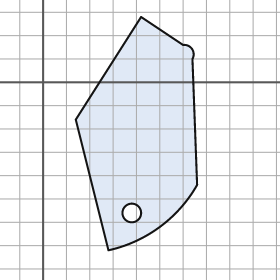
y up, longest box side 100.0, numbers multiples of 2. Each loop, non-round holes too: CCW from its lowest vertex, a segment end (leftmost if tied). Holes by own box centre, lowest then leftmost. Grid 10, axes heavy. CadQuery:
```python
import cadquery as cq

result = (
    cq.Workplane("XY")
    .moveTo(28.0, -72.0)
    .threePointArc((50.0, -62.0), (66.0, -44.0))
    .lineTo(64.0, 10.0)
    .threePointArc((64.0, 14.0), (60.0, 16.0))
    .lineTo(42.0, 28.0)
    .lineTo(14.0, -16.0)
    .close()
    .moveTo(38.0, -56.0)
    .circle(4.0)
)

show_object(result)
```